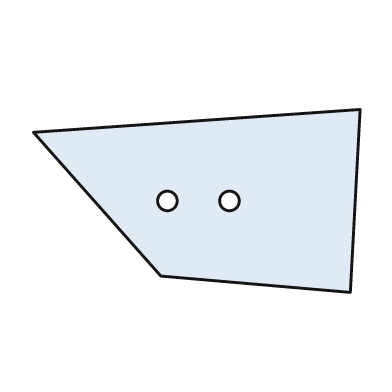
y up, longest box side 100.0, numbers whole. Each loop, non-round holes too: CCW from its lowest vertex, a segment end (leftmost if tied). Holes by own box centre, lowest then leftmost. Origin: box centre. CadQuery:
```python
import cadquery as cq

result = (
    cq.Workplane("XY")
    .moveTo(47.0, -28.0)
    .lineTo(50.0, 28.0)
    .lineTo(-50.0, 21.0)
    .lineTo(-11.0, -23.0)
    .close()
    .moveTo(-9.0, 0.0)
    .circle(3.0)
    .moveTo(10.0, 0.0)
    .circle(3.0)
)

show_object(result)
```